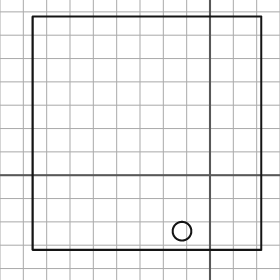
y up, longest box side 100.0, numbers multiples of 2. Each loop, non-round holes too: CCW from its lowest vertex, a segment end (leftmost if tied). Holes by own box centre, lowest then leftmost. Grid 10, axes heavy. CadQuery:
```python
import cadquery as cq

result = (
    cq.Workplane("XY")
    .moveTo(-76.0, -32.0)
    .lineTo(22.0, -32.0)
    .lineTo(22.0, 68.0)
    .lineTo(-76.0, 68.0)
    .close()
    .moveTo(-12.0, -24.0)
    .circle(4.0)
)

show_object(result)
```